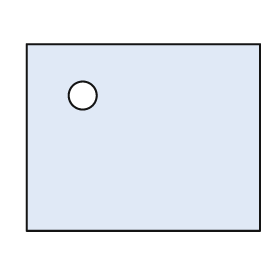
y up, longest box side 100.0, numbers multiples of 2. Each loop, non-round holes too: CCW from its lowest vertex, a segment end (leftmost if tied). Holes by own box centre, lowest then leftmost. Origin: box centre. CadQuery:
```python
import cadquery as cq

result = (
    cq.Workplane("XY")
    .moveTo(-50.0, -40.0)
    .lineTo(50.0, -40.0)
    .lineTo(50.0, 40.0)
    .lineTo(-50.0, 40.0)
    .close()
    .moveTo(-26.0, 18.0)
    .circle(6.0)
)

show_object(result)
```